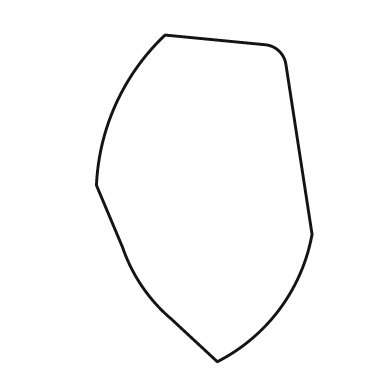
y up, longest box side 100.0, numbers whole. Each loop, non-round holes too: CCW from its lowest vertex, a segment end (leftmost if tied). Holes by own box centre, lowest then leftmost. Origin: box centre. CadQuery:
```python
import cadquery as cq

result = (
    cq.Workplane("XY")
    .moveTo(4.0, -50.0)
    .threePointArc((23.0, -34.0), (33.0, -11.0))
    .lineTo(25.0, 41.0)
    .threePointArc((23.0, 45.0), (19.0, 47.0))
    .lineTo(-12.0, 50.0)
    .threePointArc((-27.0, 29.0), (-33.0, 4.0))
    .lineTo(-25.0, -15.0)
    .threePointArc((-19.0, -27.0), (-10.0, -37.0))
    .close()
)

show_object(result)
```